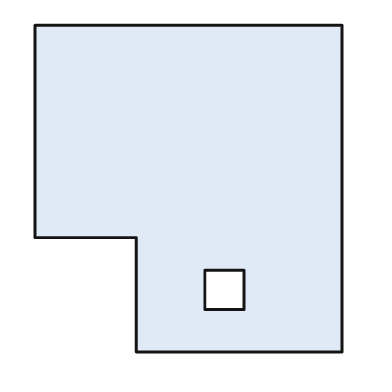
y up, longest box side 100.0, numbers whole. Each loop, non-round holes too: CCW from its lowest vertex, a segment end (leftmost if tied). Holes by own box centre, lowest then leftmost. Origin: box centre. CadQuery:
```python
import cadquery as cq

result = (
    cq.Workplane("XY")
    .moveTo(-16.0, -50.0)
    .lineTo(47.0, -50.0)
    .lineTo(47.0, 50.0)
    .lineTo(-47.0, 50.0)
    .lineTo(-47.0, -15.0)
    .lineTo(-16.0, -15.0)
    .close()
    .moveTo(5.0, -37.0)
    .lineTo(17.0, -37.0)
    .lineTo(17.0, -25.0)
    .lineTo(5.0, -25.0)
    .close()
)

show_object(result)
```